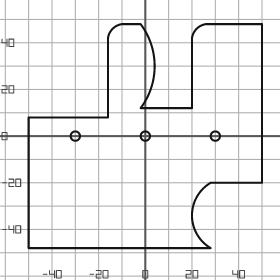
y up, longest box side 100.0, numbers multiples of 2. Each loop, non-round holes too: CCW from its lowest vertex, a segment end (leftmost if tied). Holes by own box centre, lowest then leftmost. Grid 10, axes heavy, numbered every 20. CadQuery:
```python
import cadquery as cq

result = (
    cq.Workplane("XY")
    .moveTo(-50.0, -48.0)
    .lineTo(28.0, -48.0)
    .threePointArc((20.0, -34.0), (28.0, -20.0))
    .lineTo(50.0, -20.0)
    .lineTo(50.0, 48.0)
    .lineTo(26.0, 48.0)
    .threePointArc((22.0, 46.0), (20.0, 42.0))
    .lineTo(20.0, 12.0)
    .lineTo(-2.0, 12.0)
    .threePointArc((4.0, 30.0), (-2.0, 48.0))
    .lineTo(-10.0, 48.0)
    .threePointArc((-14.0, 46.0), (-16.0, 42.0))
    .lineTo(-16.0, 8.0)
    .lineTo(-50.0, 8.0)
    .close()
    .moveTo(-30.0, 0.0)
    .circle(2.0)
    .moveTo(0.0, 0.0)
    .circle(2.0)
    .moveTo(30.0, 0.0)
    .circle(2.0)
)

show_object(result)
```